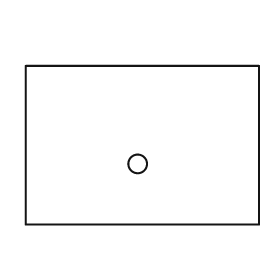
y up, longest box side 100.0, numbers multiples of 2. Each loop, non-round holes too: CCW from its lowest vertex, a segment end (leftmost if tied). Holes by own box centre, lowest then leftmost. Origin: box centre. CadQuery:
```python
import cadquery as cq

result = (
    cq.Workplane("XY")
    .moveTo(-50.0, -34.0)
    .lineTo(50.0, -34.0)
    .lineTo(50.0, 34.0)
    .lineTo(-50.0, 34.0)
    .close()
    .moveTo(-2.0, -8.0)
    .circle(4.0)
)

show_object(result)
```